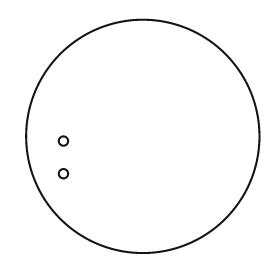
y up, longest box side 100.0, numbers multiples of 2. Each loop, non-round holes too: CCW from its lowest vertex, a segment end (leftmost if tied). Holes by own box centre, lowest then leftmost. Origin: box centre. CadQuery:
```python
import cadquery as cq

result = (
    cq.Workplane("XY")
    .moveTo(0.0, 0.0)
    .circle(50.0)
    .moveTo(-34.0, -16.0)
    .circle(2.0)
    .moveTo(-34.0, -2.0)
    .circle(2.0)
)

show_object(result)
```